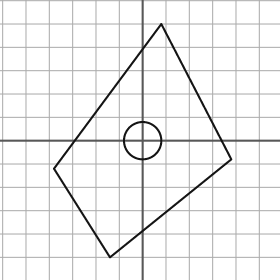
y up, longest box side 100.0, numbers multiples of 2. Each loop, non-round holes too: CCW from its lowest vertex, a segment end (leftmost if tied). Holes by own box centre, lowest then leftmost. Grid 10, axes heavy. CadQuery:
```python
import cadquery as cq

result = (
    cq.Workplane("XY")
    .moveTo(-14.0, -50.0)
    .lineTo(38.0, -8.0)
    .lineTo(8.0, 50.0)
    .lineTo(-38.0, -12.0)
    .close()
    .moveTo(0.0, 0.0)
    .circle(8.0)
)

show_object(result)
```